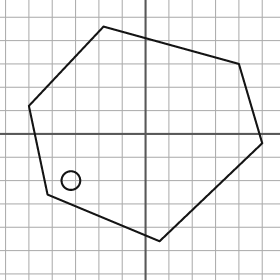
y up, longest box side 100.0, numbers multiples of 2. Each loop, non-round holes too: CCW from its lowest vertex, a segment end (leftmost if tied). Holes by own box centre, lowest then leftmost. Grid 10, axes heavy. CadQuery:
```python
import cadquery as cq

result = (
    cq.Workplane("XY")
    .moveTo(6.0, -46.0)
    .lineTo(50.0, -4.0)
    .lineTo(40.0, 30.0)
    .lineTo(-18.0, 46.0)
    .lineTo(-50.0, 12.0)
    .lineTo(-42.0, -26.0)
    .close()
    .moveTo(-32.0, -20.0)
    .circle(4.0)
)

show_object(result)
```